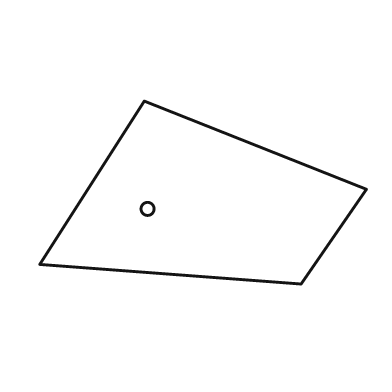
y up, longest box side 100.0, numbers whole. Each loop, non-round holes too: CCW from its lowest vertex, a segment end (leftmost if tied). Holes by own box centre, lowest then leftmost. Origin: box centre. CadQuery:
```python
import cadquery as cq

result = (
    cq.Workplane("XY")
    .moveTo(30.0, -28.0)
    .lineTo(50.0, 1.0)
    .lineTo(-18.0, 28.0)
    .lineTo(-50.0, -22.0)
    .close()
    .moveTo(-17.0, -5.0)
    .circle(2.0)
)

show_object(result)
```